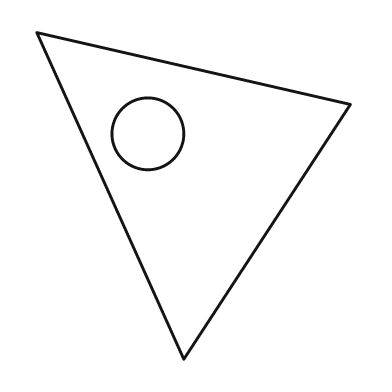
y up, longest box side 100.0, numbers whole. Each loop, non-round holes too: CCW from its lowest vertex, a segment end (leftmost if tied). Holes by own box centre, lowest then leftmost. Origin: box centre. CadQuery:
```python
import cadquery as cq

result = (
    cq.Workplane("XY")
    .moveTo(-3.0, -50.0)
    .lineTo(48.0, 28.0)
    .lineTo(-48.0, 50.0)
    .close()
    .moveTo(-14.0, 19.0)
    .circle(11.0)
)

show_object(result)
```